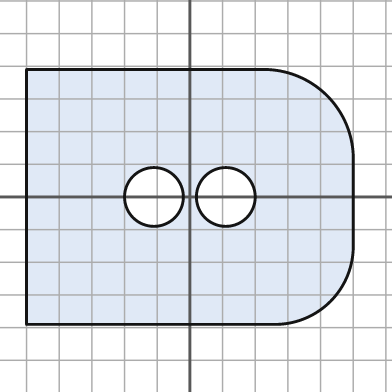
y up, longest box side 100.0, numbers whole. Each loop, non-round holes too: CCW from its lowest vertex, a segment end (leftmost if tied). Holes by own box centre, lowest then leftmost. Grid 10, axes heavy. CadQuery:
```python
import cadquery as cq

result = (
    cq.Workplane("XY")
    .moveTo(-50.0, -39.0)
    .lineTo(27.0, -39.0)
    .threePointArc((43.0, -32.0), (50.0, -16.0))
    .lineTo(50.0, 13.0)
    .threePointArc((42.0, 31.0), (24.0, 39.0))
    .lineTo(-50.0, 39.0)
    .close()
    .moveTo(-11.0, 0.0)
    .circle(9.0)
    .moveTo(11.0, 0.0)
    .circle(9.0)
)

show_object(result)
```